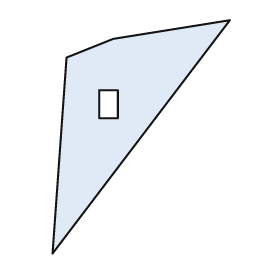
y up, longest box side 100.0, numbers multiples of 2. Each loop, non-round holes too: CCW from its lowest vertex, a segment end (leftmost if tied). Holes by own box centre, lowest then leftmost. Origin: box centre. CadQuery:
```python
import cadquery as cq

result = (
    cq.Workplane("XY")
    .moveTo(-38.0, -50.0)
    .lineTo(38.0, 50.0)
    .lineTo(-12.0, 42.0)
    .lineTo(-32.0, 34.0)
    .close()
    .moveTo(-18.0, 8.0)
    .lineTo(-10.0, 8.0)
    .lineTo(-10.0, 20.0)
    .lineTo(-18.0, 20.0)
    .close()
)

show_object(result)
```